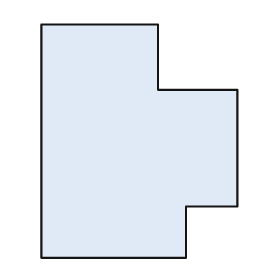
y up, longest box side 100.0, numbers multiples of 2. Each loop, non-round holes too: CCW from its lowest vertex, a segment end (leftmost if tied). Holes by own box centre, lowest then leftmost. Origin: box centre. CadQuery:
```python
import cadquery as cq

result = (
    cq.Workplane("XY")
    .moveTo(-42.0, -50.0)
    .lineTo(20.0, -50.0)
    .lineTo(20.0, -28.0)
    .lineTo(42.0, -28.0)
    .lineTo(42.0, 22.0)
    .lineTo(8.0, 22.0)
    .lineTo(8.0, 50.0)
    .lineTo(-42.0, 50.0)
    .close()
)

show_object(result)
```